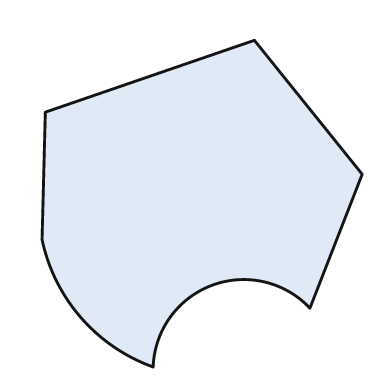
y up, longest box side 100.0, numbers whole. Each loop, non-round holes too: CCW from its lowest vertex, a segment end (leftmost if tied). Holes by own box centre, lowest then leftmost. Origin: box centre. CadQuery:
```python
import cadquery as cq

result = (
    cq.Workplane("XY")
    .moveTo(-15.0, -50.0)
    .threePointArc((3.0, -25.0), (33.0, -32.0))
    .lineTo(49.0, 9.0)
    .lineTo(16.0, 50.0)
    .lineTo(-48.0, 28.0)
    .lineTo(-49.0, -11.0)
    .threePointArc((-37.0, -35.0), (-15.0, -50.0))
    .close()
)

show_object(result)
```